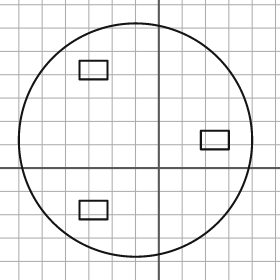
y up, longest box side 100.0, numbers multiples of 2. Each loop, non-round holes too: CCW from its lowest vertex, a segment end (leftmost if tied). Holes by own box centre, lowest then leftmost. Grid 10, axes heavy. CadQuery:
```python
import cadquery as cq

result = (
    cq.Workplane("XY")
    .moveTo(-10.0, 12.0)
    .circle(50.0)
    .moveTo(-34.0, -22.0)
    .lineTo(-22.0, -22.0)
    .lineTo(-22.0, -14.0)
    .lineTo(-34.0, -14.0)
    .close()
    .moveTo(18.0, 8.0)
    .lineTo(30.0, 8.0)
    .lineTo(30.0, 16.0)
    .lineTo(18.0, 16.0)
    .close()
    .moveTo(-34.0, 38.0)
    .lineTo(-22.0, 38.0)
    .lineTo(-22.0, 46.0)
    .lineTo(-34.0, 46.0)
    .close()
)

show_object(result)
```